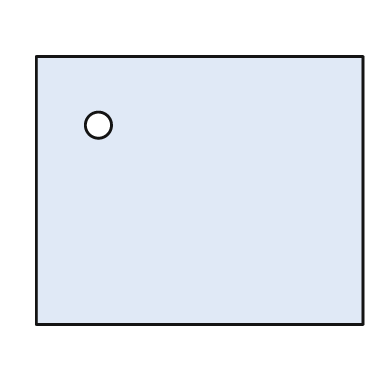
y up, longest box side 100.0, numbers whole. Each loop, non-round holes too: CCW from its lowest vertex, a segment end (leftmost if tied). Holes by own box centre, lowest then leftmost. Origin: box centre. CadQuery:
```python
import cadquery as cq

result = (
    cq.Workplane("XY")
    .moveTo(-50.0, -41.0)
    .lineTo(50.0, -41.0)
    .lineTo(50.0, 41.0)
    .lineTo(-50.0, 41.0)
    .close()
    .moveTo(-31.0, 20.0)
    .circle(4.0)
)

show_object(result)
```